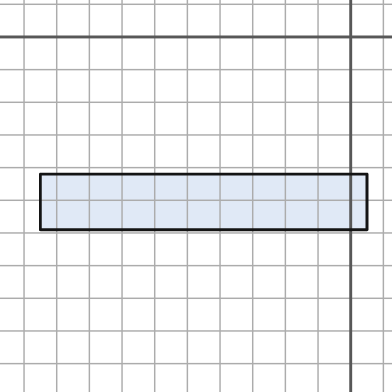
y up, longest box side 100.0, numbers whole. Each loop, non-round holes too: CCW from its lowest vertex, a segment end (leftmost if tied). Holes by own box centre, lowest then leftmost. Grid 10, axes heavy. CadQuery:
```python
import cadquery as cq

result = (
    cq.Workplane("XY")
    .moveTo(-95.0, -59.0)
    .lineTo(5.0, -59.0)
    .lineTo(5.0, -42.0)
    .lineTo(-95.0, -42.0)
    .close()
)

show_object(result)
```